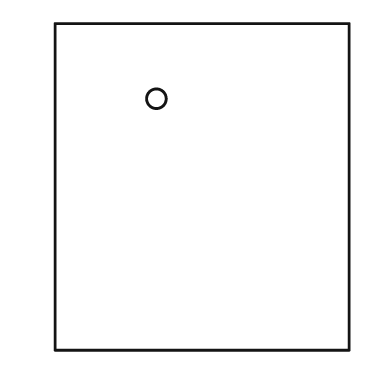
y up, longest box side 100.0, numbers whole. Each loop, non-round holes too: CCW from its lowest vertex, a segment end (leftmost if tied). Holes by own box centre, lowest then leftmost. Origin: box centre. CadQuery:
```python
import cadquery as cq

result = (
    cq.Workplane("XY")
    .moveTo(-45.0, -50.0)
    .lineTo(45.0, -50.0)
    .lineTo(45.0, 50.0)
    .lineTo(-45.0, 50.0)
    .close()
    .moveTo(-14.0, 27.0)
    .circle(3.0)
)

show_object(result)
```